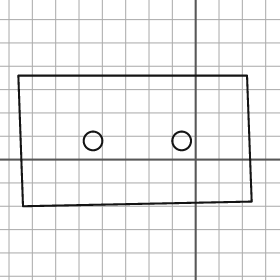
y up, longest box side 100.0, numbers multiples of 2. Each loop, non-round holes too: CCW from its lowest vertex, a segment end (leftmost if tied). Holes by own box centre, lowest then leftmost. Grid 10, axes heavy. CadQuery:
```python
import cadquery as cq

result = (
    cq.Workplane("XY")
    .moveTo(-74.0, -20.0)
    .lineTo(24.0, -18.0)
    .lineTo(22.0, 36.0)
    .lineTo(-76.0, 36.0)
    .close()
    .moveTo(-44.0, 8.0)
    .circle(4.0)
    .moveTo(-6.0, 8.0)
    .circle(4.0)
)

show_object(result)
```